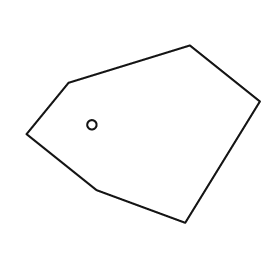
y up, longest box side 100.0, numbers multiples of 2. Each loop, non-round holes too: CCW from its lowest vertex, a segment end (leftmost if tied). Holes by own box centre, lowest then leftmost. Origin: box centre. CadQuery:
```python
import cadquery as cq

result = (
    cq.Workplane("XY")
    .moveTo(18.0, -38.0)
    .lineTo(50.0, 14.0)
    .lineTo(20.0, 38.0)
    .lineTo(-32.0, 22.0)
    .lineTo(-50.0, 0.0)
    .lineTo(-20.0, -24.0)
    .close()
    .moveTo(-22.0, 4.0)
    .circle(2.0)
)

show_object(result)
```